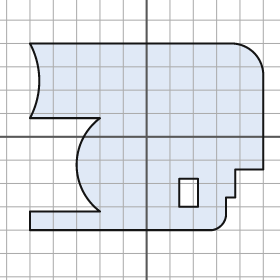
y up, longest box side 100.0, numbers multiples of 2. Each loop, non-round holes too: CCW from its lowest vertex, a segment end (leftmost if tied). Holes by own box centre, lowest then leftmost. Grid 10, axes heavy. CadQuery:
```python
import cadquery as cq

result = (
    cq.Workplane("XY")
    .moveTo(-50.0, -40.0)
    .lineTo(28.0, -40.0)
    .threePointArc((32.0, -38.0), (34.0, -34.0))
    .lineTo(34.0, -26.0)
    .lineTo(38.0, -26.0)
    .lineTo(38.0, -14.0)
    .lineTo(50.0, -14.0)
    .lineTo(50.0, 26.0)
    .threePointArc((46.0, 36.0), (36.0, 40.0))
    .lineTo(-50.0, 40.0)
    .threePointArc((-46.0, 24.0), (-50.0, 8.0))
    .lineTo(-20.0, 8.0)
    .threePointArc((-30.0, -12.0), (-20.0, -32.0))
    .lineTo(-50.0, -32.0)
    .close()
    .moveTo(14.0, -30.0)
    .lineTo(22.0, -30.0)
    .lineTo(22.0, -18.0)
    .lineTo(14.0, -18.0)
    .close()
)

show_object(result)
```